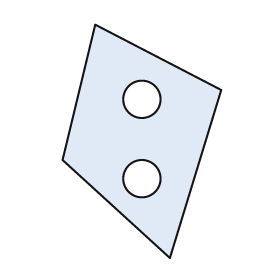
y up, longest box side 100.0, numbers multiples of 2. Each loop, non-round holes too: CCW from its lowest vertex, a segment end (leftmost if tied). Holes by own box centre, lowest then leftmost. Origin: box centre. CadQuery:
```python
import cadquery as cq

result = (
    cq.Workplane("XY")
    .moveTo(12.0, -50.0)
    .lineTo(34.0, 22.0)
    .lineTo(-20.0, 50.0)
    .lineTo(-34.0, -8.0)
    .close()
    .moveTo(0.0, -16.0)
    .circle(8.0)
    .moveTo(0.0, 18.0)
    .circle(8.0)
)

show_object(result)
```